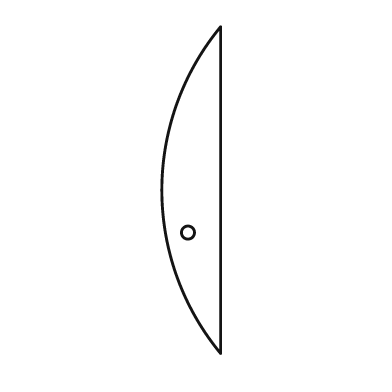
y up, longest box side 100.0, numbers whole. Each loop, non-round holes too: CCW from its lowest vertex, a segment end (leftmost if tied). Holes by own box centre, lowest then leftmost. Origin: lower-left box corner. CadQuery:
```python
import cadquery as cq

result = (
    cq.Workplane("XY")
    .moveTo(18.0, 0.0)
    .lineTo(18.0, 100.0)
    .threePointArc((0.0, 50.0), (18.0, 0.0))
    .close()
    .moveTo(8.0, 37.0)
    .circle(2.0)
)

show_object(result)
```